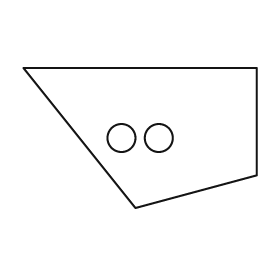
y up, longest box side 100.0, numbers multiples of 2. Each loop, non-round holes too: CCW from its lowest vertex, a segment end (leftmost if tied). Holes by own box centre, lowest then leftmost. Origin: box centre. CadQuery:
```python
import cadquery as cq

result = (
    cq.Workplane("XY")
    .moveTo(-2.0, -30.0)
    .lineTo(50.0, -16.0)
    .lineTo(50.0, 30.0)
    .lineTo(-50.0, 30.0)
    .close()
    .moveTo(-8.0, 0.0)
    .circle(6.0)
    .moveTo(8.0, 0.0)
    .circle(6.0)
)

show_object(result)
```